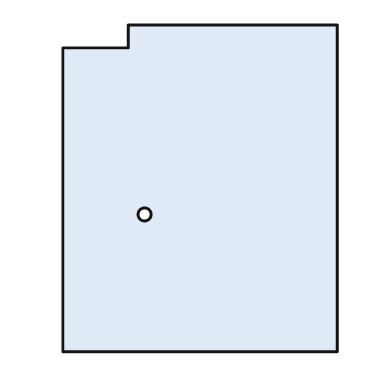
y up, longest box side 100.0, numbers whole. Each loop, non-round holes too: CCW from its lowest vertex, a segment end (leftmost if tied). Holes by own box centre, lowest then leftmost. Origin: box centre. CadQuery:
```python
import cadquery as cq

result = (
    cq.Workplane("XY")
    .moveTo(-42.0, -50.0)
    .lineTo(42.0, -50.0)
    .lineTo(42.0, 50.0)
    .lineTo(-22.0, 50.0)
    .lineTo(-22.0, 43.0)
    .lineTo(-42.0, 43.0)
    .close()
    .moveTo(-17.0, -8.0)
    .circle(2.0)
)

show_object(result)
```